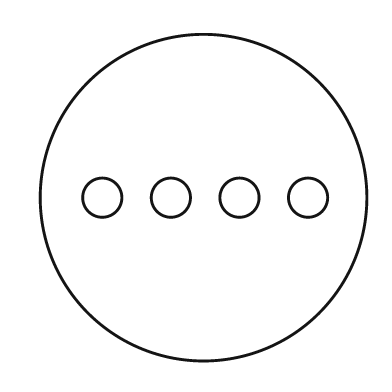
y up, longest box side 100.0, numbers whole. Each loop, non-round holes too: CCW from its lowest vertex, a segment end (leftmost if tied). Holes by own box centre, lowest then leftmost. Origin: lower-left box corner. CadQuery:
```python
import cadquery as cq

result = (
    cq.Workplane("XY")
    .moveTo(50.0, 50.0)
    .circle(50.0)
    .moveTo(19.0, 50.0)
    .circle(6.0)
    .moveTo(40.0, 50.0)
    .circle(6.0)
    .moveTo(61.0, 50.0)
    .circle(6.0)
    .moveTo(82.0, 50.0)
    .circle(6.0)
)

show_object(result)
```